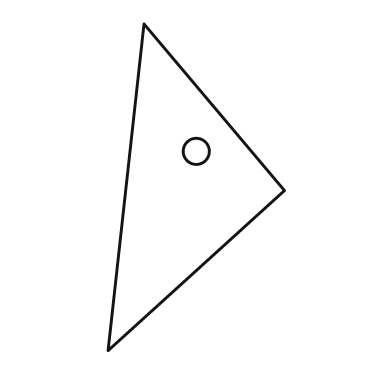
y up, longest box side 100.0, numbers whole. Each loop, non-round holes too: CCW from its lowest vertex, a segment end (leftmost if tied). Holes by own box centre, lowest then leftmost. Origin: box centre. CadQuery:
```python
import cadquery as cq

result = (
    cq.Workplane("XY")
    .moveTo(-27.0, -50.0)
    .lineTo(27.0, -1.0)
    .lineTo(-16.0, 50.0)
    .close()
    .moveTo(0.0, 11.0)
    .circle(4.0)
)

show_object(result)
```